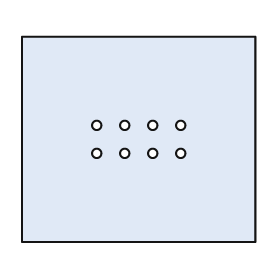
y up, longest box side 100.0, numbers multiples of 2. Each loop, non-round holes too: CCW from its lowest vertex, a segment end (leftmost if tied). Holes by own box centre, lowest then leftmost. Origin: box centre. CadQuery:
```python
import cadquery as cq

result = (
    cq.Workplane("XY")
    .moveTo(-50.0, -44.0)
    .lineTo(50.0, -44.0)
    .lineTo(50.0, 44.0)
    .lineTo(-50.0, 44.0)
    .close()
    .moveTo(-18.0, -6.0)
    .circle(2.0)
    .moveTo(-6.0, -6.0)
    .circle(2.0)
    .moveTo(6.0, -6.0)
    .circle(2.0)
    .moveTo(18.0, -6.0)
    .circle(2.0)
    .moveTo(-18.0, 6.0)
    .circle(2.0)
    .moveTo(-6.0, 6.0)
    .circle(2.0)
    .moveTo(6.0, 6.0)
    .circle(2.0)
    .moveTo(18.0, 6.0)
    .circle(2.0)
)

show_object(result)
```